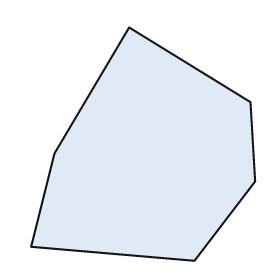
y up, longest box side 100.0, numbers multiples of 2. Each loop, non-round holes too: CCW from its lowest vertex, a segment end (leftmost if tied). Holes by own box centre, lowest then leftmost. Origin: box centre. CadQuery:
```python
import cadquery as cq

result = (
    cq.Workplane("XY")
    .moveTo(22.0, -50.0)
    .lineTo(48.0, -16.0)
    .lineTo(46.0, 18.0)
    .lineTo(-6.0, 50.0)
    .lineTo(-38.0, -4.0)
    .lineTo(-48.0, -44.0)
    .close()
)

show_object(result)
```